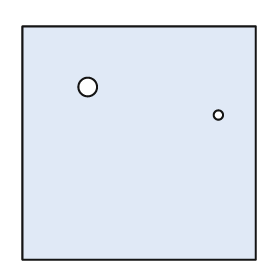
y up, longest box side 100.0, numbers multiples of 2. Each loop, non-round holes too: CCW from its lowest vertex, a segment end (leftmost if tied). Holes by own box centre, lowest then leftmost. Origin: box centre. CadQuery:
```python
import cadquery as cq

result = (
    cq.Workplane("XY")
    .moveTo(-50.0, -50.0)
    .lineTo(50.0, -50.0)
    .lineTo(50.0, 50.0)
    .lineTo(-50.0, 50.0)
    .close()
    .moveTo(34.0, 12.0)
    .circle(2.0)
    .moveTo(-22.0, 24.0)
    .circle(4.0)
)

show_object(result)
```